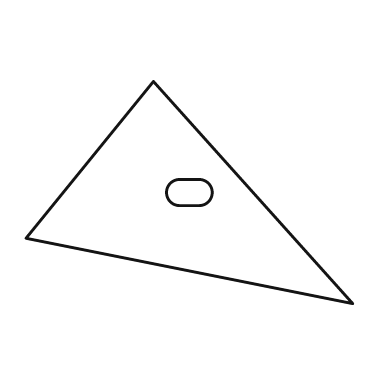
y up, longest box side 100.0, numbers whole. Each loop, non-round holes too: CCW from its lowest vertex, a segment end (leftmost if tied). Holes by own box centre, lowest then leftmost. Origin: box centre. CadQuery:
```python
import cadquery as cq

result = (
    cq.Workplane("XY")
    .moveTo(50.0, -34.0)
    .lineTo(-11.0, 34.0)
    .lineTo(-50.0, -14.0)
    .close()
    .moveTo(-3.0, -4.0)
    .lineTo(3.0, -4.0)
    .threePointArc((7.0, 0.0), (3.0, 4.0))
    .lineTo(-3.0, 4.0)
    .threePointArc((-7.0, 0.0), (-3.0, -4.0))
    .close()
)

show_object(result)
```